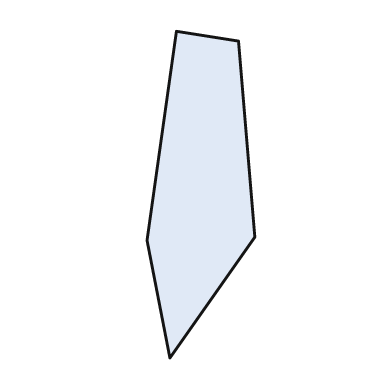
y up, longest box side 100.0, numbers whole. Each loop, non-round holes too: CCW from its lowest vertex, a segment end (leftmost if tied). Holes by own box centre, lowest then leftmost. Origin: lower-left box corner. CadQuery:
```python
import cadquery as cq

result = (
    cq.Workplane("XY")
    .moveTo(7.0, 0.0)
    .lineTo(33.0, 37.0)
    .lineTo(28.0, 97.0)
    .lineTo(9.0, 100.0)
    .lineTo(0.0, 36.0)
    .close()
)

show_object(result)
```